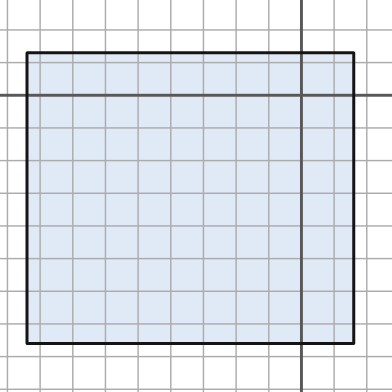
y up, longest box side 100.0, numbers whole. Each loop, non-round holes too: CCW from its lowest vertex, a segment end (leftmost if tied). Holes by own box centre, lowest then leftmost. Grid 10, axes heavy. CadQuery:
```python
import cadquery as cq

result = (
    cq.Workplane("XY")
    .moveTo(-84.0, -76.0)
    .lineTo(16.0, -76.0)
    .lineTo(16.0, 13.0)
    .lineTo(-84.0, 13.0)
    .close()
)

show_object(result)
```